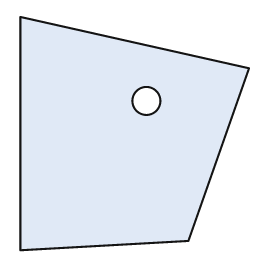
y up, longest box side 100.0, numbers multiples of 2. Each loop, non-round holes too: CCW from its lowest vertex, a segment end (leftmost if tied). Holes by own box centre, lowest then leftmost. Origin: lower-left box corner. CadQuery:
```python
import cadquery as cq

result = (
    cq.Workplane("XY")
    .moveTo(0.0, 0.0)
    .lineTo(72.0, 4.0)
    .lineTo(98.0, 78.0)
    .lineTo(0.0, 100.0)
    .close()
    .moveTo(54.0, 64.0)
    .circle(6.0)
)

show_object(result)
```